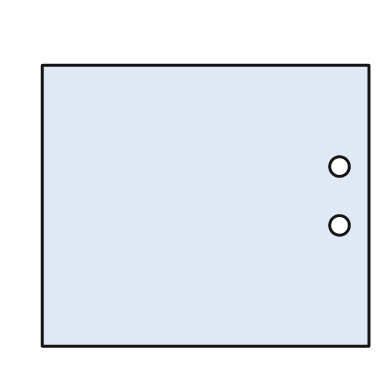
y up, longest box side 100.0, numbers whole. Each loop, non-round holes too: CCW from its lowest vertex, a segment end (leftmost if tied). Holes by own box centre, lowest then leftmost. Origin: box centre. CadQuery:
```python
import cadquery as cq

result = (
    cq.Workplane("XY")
    .moveTo(-50.0, -43.0)
    .lineTo(50.0, -43.0)
    .lineTo(50.0, 43.0)
    .lineTo(-50.0, 43.0)
    .close()
    .moveTo(41.0, -6.0)
    .circle(3.0)
    .moveTo(41.0, 12.0)
    .circle(3.0)
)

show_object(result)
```